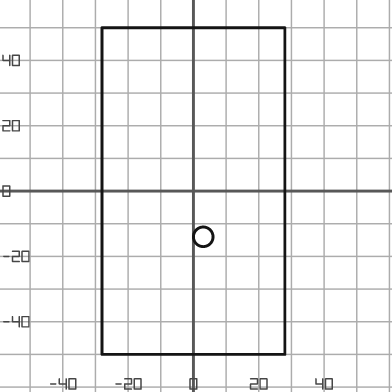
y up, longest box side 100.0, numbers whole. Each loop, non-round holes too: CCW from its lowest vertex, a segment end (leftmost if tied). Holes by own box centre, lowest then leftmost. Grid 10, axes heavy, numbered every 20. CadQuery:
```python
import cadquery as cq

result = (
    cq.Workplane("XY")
    .moveTo(-28.0, -50.0)
    .lineTo(28.0, -50.0)
    .lineTo(28.0, 50.0)
    .lineTo(-28.0, 50.0)
    .close()
    .moveTo(3.0, -14.0)
    .circle(3.0)
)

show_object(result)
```